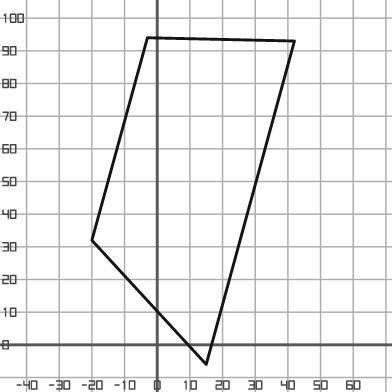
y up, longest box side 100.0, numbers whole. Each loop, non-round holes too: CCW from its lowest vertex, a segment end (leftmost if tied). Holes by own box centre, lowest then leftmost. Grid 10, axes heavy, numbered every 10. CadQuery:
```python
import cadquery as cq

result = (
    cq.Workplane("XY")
    .moveTo(15.0, -6.0)
    .lineTo(42.0, 93.0)
    .lineTo(-3.0, 94.0)
    .lineTo(-20.0, 32.0)
    .close()
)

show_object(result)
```